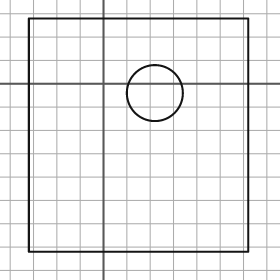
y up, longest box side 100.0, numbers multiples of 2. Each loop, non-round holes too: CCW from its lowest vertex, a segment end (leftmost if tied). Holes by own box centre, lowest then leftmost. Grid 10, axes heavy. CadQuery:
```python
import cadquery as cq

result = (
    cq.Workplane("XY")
    .moveTo(-32.0, -72.0)
    .lineTo(62.0, -72.0)
    .lineTo(62.0, 28.0)
    .lineTo(-32.0, 28.0)
    .close()
    .moveTo(22.0, -4.0)
    .circle(12.0)
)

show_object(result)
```